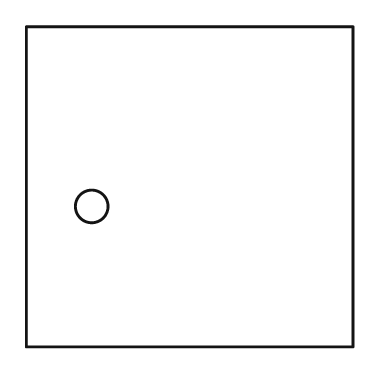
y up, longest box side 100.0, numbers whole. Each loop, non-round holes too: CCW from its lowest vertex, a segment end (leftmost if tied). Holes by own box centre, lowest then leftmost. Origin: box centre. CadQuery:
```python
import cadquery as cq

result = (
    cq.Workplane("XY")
    .moveTo(-50.0, -49.0)
    .lineTo(50.0, -49.0)
    .lineTo(50.0, 49.0)
    .lineTo(-50.0, 49.0)
    .close()
    .moveTo(-30.0, -6.0)
    .circle(5.0)
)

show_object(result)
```